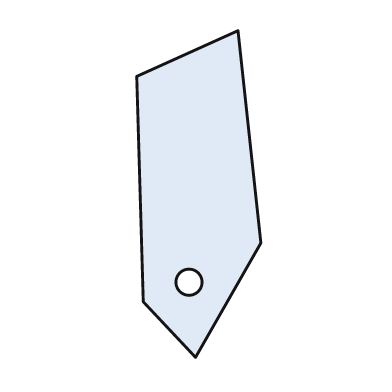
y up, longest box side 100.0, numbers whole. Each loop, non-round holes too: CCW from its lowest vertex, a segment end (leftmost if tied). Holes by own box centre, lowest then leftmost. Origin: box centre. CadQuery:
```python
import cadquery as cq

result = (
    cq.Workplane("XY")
    .moveTo(-1.0, -50.0)
    .lineTo(19.0, -15.0)
    .lineTo(12.0, 50.0)
    .lineTo(-19.0, 36.0)
    .lineTo(-17.0, -33.0)
    .close()
    .moveTo(-3.0, -27.0)
    .circle(4.0)
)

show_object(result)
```